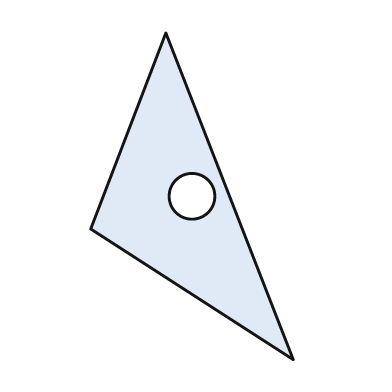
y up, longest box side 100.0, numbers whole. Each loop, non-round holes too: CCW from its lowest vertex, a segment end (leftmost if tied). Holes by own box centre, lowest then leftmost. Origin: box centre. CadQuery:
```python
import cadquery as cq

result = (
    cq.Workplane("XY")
    .moveTo(31.0, -50.0)
    .lineTo(-8.0, 50.0)
    .lineTo(-31.0, -10.0)
    .close()
    .moveTo(0.0, 0.0)
    .circle(7.0)
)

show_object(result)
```